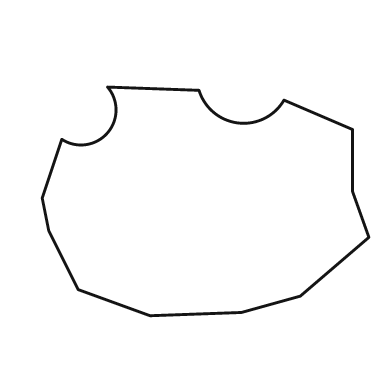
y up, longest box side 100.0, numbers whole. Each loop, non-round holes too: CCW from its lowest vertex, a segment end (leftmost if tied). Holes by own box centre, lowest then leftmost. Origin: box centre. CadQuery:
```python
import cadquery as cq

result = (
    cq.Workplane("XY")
    .moveTo(-17.0, -35.0)
    .lineTo(11.0, -34.0)
    .lineTo(29.0, -29.0)
    .lineTo(50.0, -11.0)
    .lineTo(45.0, 3.0)
    .lineTo(45.0, 22.0)
    .lineTo(24.0, 31.0)
    .threePointArc((10.0, 24.0), (-2.0, 34.0))
    .lineTo(-30.0, 35.0)
    .threePointArc((-30.0, 21.0), (-44.0, 19.0))
    .lineTo(-50.0, 1.0)
    .lineTo(-48.0, -9.0)
    .lineTo(-39.0, -27.0)
    .close()
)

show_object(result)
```